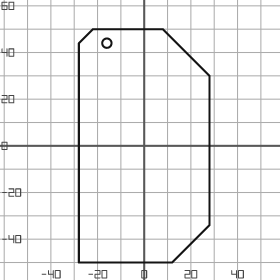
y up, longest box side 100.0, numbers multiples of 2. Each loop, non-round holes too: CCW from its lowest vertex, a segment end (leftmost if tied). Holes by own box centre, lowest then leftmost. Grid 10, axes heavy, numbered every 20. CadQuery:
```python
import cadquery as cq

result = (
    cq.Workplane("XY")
    .moveTo(-28.0, -50.0)
    .lineTo(12.0, -50.0)
    .lineTo(28.0, -34.0)
    .lineTo(28.0, 30.0)
    .lineTo(8.0, 50.0)
    .lineTo(-22.0, 50.0)
    .lineTo(-28.0, 44.0)
    .close()
    .moveTo(-16.0, 44.0)
    .circle(2.0)
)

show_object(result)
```